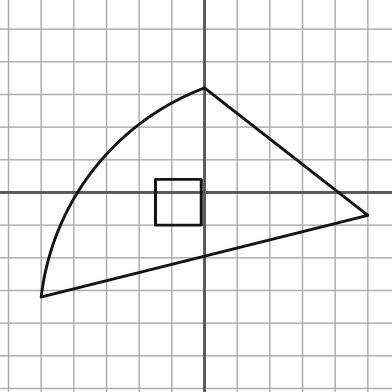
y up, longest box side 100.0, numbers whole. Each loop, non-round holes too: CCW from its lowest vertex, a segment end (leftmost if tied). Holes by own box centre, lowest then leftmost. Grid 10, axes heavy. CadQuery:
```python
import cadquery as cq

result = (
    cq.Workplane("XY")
    .moveTo(-50.0, -32.0)
    .lineTo(50.0, -7.0)
    .lineTo(0.0, 32.0)
    .threePointArc((-34.0, 7.0), (-50.0, -32.0))
    .close()
    .moveTo(-15.0, -10.0)
    .lineTo(-1.0, -10.0)
    .lineTo(-1.0, 4.0)
    .lineTo(-15.0, 4.0)
    .close()
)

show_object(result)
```